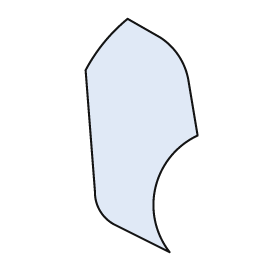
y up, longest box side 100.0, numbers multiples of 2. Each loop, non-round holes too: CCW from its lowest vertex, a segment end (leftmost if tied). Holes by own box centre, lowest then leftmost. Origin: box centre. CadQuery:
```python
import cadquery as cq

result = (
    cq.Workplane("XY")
    .moveTo(12.0, -50.0)
    .threePointArc((6.0, -22.0), (24.0, 0.0))
    .lineTo(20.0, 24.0)
    .threePointArc((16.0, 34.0), (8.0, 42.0))
    .lineTo(-6.0, 50.0)
    .threePointArc((-16.0, 40.0), (-24.0, 28.0))
    .lineTo(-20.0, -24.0)
    .threePointArc((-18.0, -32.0), (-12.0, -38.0))
    .close()
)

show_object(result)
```